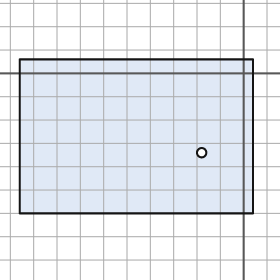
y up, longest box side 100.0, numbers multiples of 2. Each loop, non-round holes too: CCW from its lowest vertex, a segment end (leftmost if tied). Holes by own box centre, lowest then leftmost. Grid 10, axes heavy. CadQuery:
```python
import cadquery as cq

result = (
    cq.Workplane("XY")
    .moveTo(-96.0, -60.0)
    .lineTo(4.0, -60.0)
    .lineTo(4.0, 6.0)
    .lineTo(-96.0, 6.0)
    .close()
    .moveTo(-18.0, -34.0)
    .circle(2.0)
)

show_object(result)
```